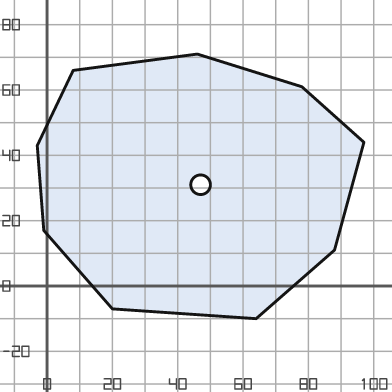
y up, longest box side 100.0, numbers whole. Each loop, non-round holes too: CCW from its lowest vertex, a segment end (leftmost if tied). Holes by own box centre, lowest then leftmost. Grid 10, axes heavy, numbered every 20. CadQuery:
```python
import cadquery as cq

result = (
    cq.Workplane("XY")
    .moveTo(64.0, -10.0)
    .lineTo(88.0, 11.0)
    .lineTo(97.0, 44.0)
    .lineTo(78.0, 61.0)
    .lineTo(46.0, 71.0)
    .lineTo(8.0, 66.0)
    .lineTo(-3.0, 43.0)
    .lineTo(-1.0, 17.0)
    .lineTo(20.0, -7.0)
    .close()
    .moveTo(47.0, 31.0)
    .circle(3.0)
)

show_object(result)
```